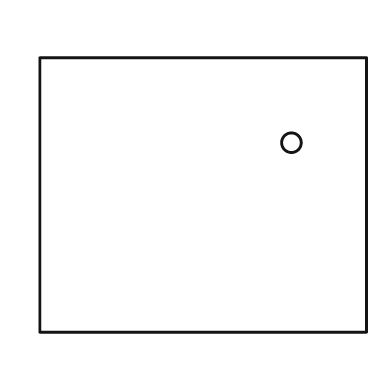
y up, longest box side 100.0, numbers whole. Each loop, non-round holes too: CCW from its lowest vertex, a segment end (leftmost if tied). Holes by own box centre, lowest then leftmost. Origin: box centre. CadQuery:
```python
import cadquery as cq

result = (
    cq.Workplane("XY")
    .moveTo(-50.0, -42.0)
    .lineTo(50.0, -42.0)
    .lineTo(50.0, 42.0)
    .lineTo(-50.0, 42.0)
    .close()
    .moveTo(27.0, 16.0)
    .circle(3.0)
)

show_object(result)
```